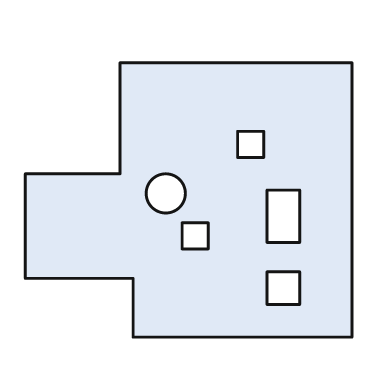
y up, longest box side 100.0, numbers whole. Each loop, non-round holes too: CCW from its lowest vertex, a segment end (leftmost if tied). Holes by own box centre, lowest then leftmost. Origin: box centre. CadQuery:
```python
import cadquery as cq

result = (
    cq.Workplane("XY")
    .moveTo(-17.0, -42.0)
    .lineTo(50.0, -42.0)
    .lineTo(50.0, 42.0)
    .lineTo(-21.0, 42.0)
    .lineTo(-21.0, 8.0)
    .lineTo(-50.0, 8.0)
    .lineTo(-50.0, -24.0)
    .lineTo(-17.0, -24.0)
    .close()
    .moveTo(24.0, -32.0)
    .lineTo(34.0, -32.0)
    .lineTo(34.0, -22.0)
    .lineTo(24.0, -22.0)
    .close()
    .moveTo(-2.0, -15.0)
    .lineTo(6.0, -15.0)
    .lineTo(6.0, -7.0)
    .lineTo(-2.0, -7.0)
    .close()
    .moveTo(24.0, -13.0)
    .lineTo(34.0, -13.0)
    .lineTo(34.0, 3.0)
    .lineTo(24.0, 3.0)
    .close()
    .moveTo(-7.0, 2.0)
    .circle(6.0)
    .moveTo(15.0, 13.0)
    .lineTo(23.0, 13.0)
    .lineTo(23.0, 21.0)
    .lineTo(15.0, 21.0)
    .close()
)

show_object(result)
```